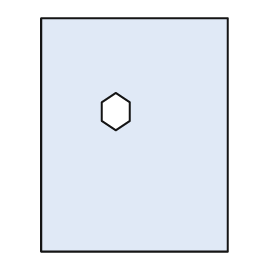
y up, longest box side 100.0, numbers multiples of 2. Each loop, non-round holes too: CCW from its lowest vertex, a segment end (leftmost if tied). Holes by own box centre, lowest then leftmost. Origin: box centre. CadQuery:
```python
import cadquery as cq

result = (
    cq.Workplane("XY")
    .moveTo(-40.0, -50.0)
    .lineTo(40.0, -50.0)
    .lineTo(40.0, 50.0)
    .lineTo(-40.0, 50.0)
    .close()
    .moveTo(-8.0, 2.0)
    .lineTo(-2.0, 6.0)
    .lineTo(-2.0, 14.0)
    .lineTo(-8.0, 18.0)
    .lineTo(-14.0, 14.0)
    .lineTo(-14.0, 6.0)
    .close()
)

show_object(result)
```